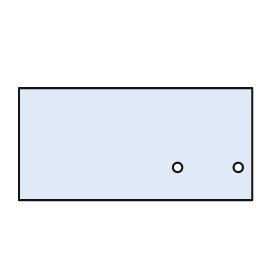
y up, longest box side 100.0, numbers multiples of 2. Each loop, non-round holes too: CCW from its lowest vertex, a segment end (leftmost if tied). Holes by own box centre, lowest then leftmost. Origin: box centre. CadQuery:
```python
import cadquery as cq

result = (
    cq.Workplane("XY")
    .moveTo(-50.0, -24.0)
    .lineTo(50.0, -24.0)
    .lineTo(50.0, 24.0)
    .lineTo(-50.0, 24.0)
    .close()
    .moveTo(18.0, -10.0)
    .circle(2.0)
    .moveTo(44.0, -10.0)
    .circle(2.0)
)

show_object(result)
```